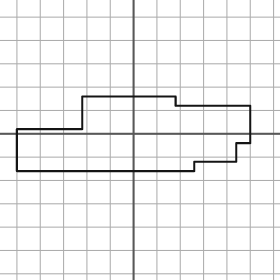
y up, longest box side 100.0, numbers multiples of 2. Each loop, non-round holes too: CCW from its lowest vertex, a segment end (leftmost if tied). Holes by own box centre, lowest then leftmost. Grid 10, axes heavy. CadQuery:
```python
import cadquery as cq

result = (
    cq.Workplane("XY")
    .moveTo(-50.0, -16.0)
    .lineTo(26.0, -16.0)
    .lineTo(26.0, -12.0)
    .lineTo(44.0, -12.0)
    .lineTo(44.0, -4.0)
    .lineTo(50.0, -4.0)
    .lineTo(50.0, 12.0)
    .lineTo(18.0, 12.0)
    .lineTo(18.0, 16.0)
    .lineTo(-22.0, 16.0)
    .lineTo(-22.0, 2.0)
    .lineTo(-50.0, 2.0)
    .close()
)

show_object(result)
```